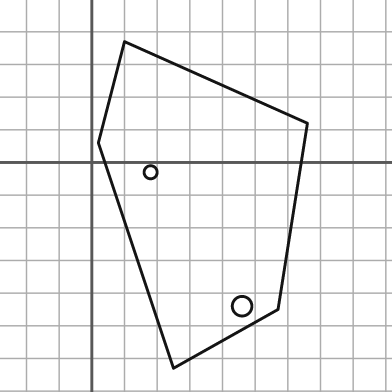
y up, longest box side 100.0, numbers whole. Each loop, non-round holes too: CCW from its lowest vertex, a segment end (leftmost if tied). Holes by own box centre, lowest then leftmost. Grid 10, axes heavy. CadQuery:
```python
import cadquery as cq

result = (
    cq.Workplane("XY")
    .moveTo(25.0, -63.0)
    .lineTo(57.0, -45.0)
    .lineTo(66.0, 12.0)
    .lineTo(10.0, 37.0)
    .lineTo(2.0, 6.0)
    .close()
    .moveTo(46.0, -44.0)
    .circle(3.0)
    .moveTo(18.0, -3.0)
    .circle(2.0)
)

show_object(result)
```